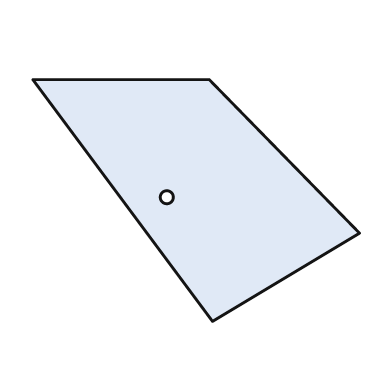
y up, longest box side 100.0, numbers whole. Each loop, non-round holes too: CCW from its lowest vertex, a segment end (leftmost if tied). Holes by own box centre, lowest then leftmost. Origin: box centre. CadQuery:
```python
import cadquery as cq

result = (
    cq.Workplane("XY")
    .moveTo(5.0, -37.0)
    .lineTo(50.0, -10.0)
    .lineTo(4.0, 37.0)
    .lineTo(-50.0, 37.0)
    .close()
    .moveTo(-9.0, 1.0)
    .circle(2.0)
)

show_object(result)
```